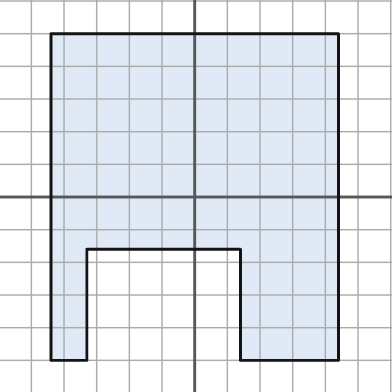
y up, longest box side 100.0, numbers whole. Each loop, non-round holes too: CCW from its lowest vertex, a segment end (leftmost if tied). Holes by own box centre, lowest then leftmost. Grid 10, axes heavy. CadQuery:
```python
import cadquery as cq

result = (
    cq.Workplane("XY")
    .moveTo(-44.0, -50.0)
    .lineTo(-33.0, -50.0)
    .lineTo(-33.0, -16.0)
    .lineTo(14.0, -16.0)
    .lineTo(14.0, -50.0)
    .lineTo(44.0, -50.0)
    .lineTo(44.0, 50.0)
    .lineTo(-44.0, 50.0)
    .close()
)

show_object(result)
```